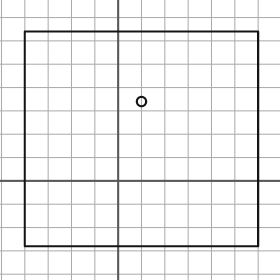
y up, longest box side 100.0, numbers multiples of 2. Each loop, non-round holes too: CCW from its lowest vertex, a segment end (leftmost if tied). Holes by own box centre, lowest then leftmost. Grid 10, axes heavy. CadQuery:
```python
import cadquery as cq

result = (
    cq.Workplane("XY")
    .moveTo(-40.0, -28.0)
    .lineTo(60.0, -28.0)
    .lineTo(60.0, 64.0)
    .lineTo(-40.0, 64.0)
    .close()
    .moveTo(10.0, 34.0)
    .circle(2.0)
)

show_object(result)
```